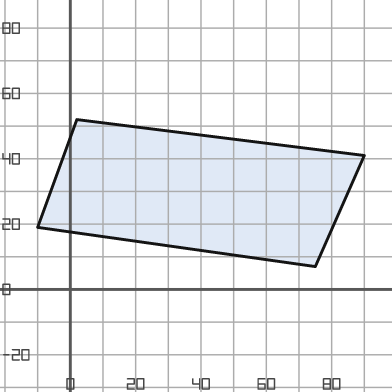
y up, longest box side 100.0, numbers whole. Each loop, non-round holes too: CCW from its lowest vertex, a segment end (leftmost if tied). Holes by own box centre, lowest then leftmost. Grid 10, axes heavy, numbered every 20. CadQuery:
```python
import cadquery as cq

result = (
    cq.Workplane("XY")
    .moveTo(75.0, 7.0)
    .lineTo(90.0, 41.0)
    .lineTo(2.0, 52.0)
    .lineTo(-10.0, 19.0)
    .close()
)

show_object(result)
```